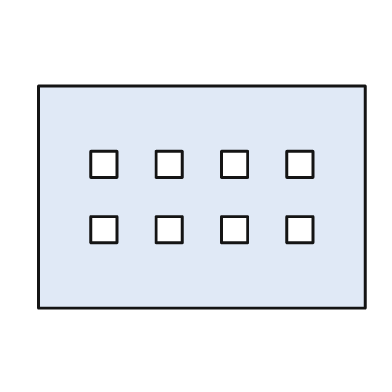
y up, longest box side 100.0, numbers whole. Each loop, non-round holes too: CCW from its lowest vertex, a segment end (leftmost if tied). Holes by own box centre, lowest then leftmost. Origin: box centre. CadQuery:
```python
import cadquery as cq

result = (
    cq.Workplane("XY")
    .moveTo(-50.0, -34.0)
    .lineTo(50.0, -34.0)
    .lineTo(50.0, 34.0)
    .lineTo(-50.0, 34.0)
    .close()
    .moveTo(-34.0, -14.0)
    .lineTo(-26.0, -14.0)
    .lineTo(-26.0, -6.0)
    .lineTo(-34.0, -6.0)
    .close()
    .moveTo(-14.0, -14.0)
    .lineTo(-6.0, -14.0)
    .lineTo(-6.0, -6.0)
    .lineTo(-14.0, -6.0)
    .close()
    .moveTo(6.0, -14.0)
    .lineTo(14.0, -14.0)
    .lineTo(14.0, -6.0)
    .lineTo(6.0, -6.0)
    .close()
    .moveTo(26.0, -14.0)
    .lineTo(34.0, -14.0)
    .lineTo(34.0, -6.0)
    .lineTo(26.0, -6.0)
    .close()
    .moveTo(-34.0, 6.0)
    .lineTo(-26.0, 6.0)
    .lineTo(-26.0, 14.0)
    .lineTo(-34.0, 14.0)
    .close()
    .moveTo(-14.0, 6.0)
    .lineTo(-6.0, 6.0)
    .lineTo(-6.0, 14.0)
    .lineTo(-14.0, 14.0)
    .close()
    .moveTo(6.0, 6.0)
    .lineTo(14.0, 6.0)
    .lineTo(14.0, 14.0)
    .lineTo(6.0, 14.0)
    .close()
    .moveTo(26.0, 6.0)
    .lineTo(34.0, 6.0)
    .lineTo(34.0, 14.0)
    .lineTo(26.0, 14.0)
    .close()
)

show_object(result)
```